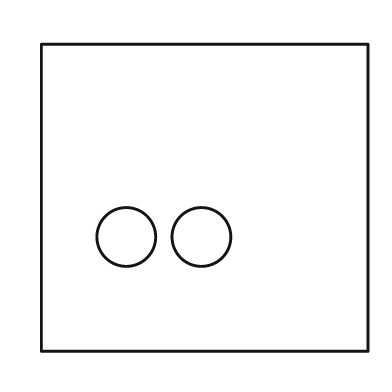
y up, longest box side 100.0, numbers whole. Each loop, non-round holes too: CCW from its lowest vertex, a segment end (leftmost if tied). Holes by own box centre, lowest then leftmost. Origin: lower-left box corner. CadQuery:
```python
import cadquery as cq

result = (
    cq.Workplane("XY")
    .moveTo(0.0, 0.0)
    .lineTo(100.0, 0.0)
    .lineTo(100.0, 94.0)
    .lineTo(0.0, 94.0)
    .close()
    .moveTo(26.0, 35.0)
    .circle(9.0)
    .moveTo(49.0, 35.0)
    .circle(9.0)
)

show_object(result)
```